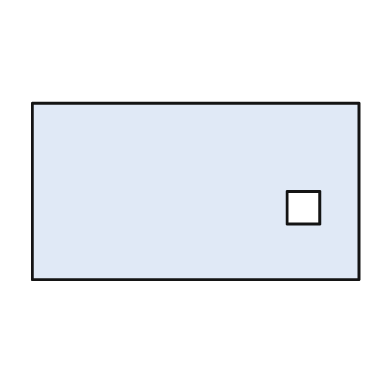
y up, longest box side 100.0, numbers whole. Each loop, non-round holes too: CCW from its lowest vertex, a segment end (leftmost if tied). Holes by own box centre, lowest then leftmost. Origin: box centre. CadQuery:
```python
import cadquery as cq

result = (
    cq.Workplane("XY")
    .moveTo(-50.0, -27.0)
    .lineTo(50.0, -27.0)
    .lineTo(50.0, 27.0)
    .lineTo(-50.0, 27.0)
    .close()
    .moveTo(28.0, -10.0)
    .lineTo(38.0, -10.0)
    .lineTo(38.0, 0.0)
    .lineTo(28.0, 0.0)
    .close()
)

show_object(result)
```